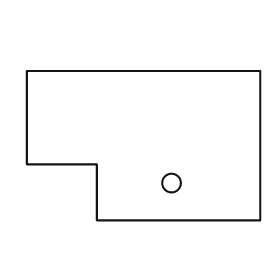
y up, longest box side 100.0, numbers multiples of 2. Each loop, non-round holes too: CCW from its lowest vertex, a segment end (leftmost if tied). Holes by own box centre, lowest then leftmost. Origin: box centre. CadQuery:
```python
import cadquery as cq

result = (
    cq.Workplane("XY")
    .moveTo(-20.0, -32.0)
    .lineTo(50.0, -32.0)
    .lineTo(50.0, 32.0)
    .lineTo(-50.0, 32.0)
    .lineTo(-50.0, -8.0)
    .lineTo(-20.0, -8.0)
    .close()
    .moveTo(12.0, -16.0)
    .circle(4.0)
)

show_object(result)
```